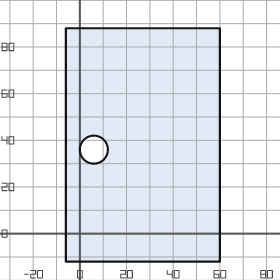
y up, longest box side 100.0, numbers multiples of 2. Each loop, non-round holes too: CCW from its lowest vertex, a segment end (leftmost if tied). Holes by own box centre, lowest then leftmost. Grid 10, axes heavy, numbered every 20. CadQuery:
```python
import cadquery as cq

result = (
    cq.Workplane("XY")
    .moveTo(-6.0, -12.0)
    .lineTo(60.0, -12.0)
    .lineTo(60.0, 88.0)
    .lineTo(-6.0, 88.0)
    .close()
    .moveTo(6.0, 36.0)
    .circle(6.0)
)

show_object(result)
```